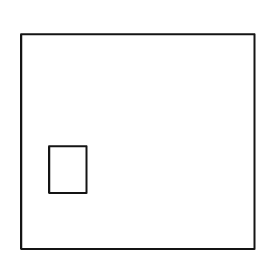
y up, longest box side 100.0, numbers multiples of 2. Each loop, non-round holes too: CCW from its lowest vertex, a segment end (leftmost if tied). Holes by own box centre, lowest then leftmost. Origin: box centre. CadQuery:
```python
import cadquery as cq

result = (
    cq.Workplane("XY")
    .moveTo(-50.0, -46.0)
    .lineTo(50.0, -46.0)
    .lineTo(50.0, 46.0)
    .lineTo(-50.0, 46.0)
    .close()
    .moveTo(-38.0, -22.0)
    .lineTo(-22.0, -22.0)
    .lineTo(-22.0, -2.0)
    .lineTo(-38.0, -2.0)
    .close()
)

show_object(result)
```